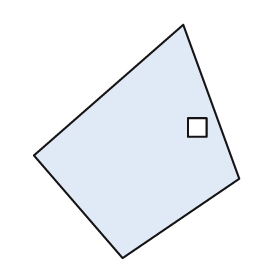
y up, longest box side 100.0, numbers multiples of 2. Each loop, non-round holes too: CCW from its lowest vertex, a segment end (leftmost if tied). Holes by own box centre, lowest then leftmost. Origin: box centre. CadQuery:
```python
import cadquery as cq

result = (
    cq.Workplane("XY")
    .moveTo(-6.0, -50.0)
    .lineTo(44.0, -16.0)
    .lineTo(20.0, 50.0)
    .lineTo(-44.0, -6.0)
    .close()
    .moveTo(22.0, 2.0)
    .lineTo(30.0, 2.0)
    .lineTo(30.0, 10.0)
    .lineTo(22.0, 10.0)
    .close()
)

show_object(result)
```